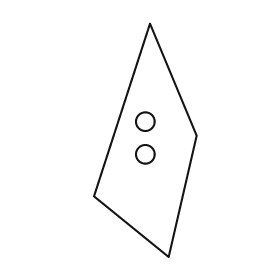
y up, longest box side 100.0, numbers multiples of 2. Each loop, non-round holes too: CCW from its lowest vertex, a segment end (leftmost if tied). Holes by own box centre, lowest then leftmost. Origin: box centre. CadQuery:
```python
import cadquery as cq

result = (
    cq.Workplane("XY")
    .moveTo(10.0, -50.0)
    .lineTo(22.0, 2.0)
    .lineTo(2.0, 50.0)
    .lineTo(-22.0, -24.0)
    .close()
    .moveTo(0.0, -6.0)
    .circle(4.0)
    .moveTo(0.0, 8.0)
    .circle(4.0)
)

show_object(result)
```